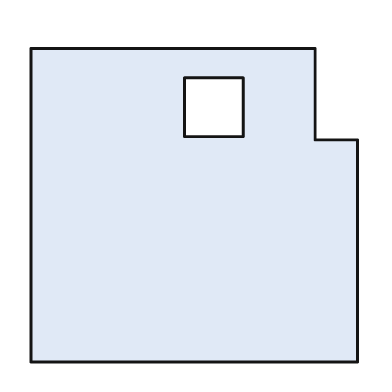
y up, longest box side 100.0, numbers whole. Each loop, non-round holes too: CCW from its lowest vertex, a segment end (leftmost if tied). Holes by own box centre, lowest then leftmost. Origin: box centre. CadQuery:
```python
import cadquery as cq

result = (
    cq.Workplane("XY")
    .moveTo(-50.0, -48.0)
    .lineTo(50.0, -48.0)
    .lineTo(50.0, 20.0)
    .lineTo(37.0, 20.0)
    .lineTo(37.0, 48.0)
    .lineTo(-50.0, 48.0)
    .close()
    .moveTo(-3.0, 21.0)
    .lineTo(15.0, 21.0)
    .lineTo(15.0, 39.0)
    .lineTo(-3.0, 39.0)
    .close()
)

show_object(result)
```